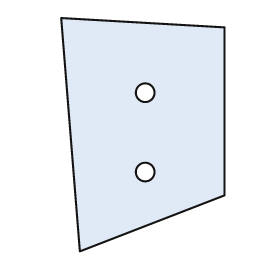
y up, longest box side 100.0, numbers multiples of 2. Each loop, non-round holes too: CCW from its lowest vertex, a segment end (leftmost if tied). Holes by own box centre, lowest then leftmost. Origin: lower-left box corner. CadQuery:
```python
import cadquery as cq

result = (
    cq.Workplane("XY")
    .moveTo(8.0, 0.0)
    .lineTo(70.0, 24.0)
    .lineTo(70.0, 96.0)
    .lineTo(0.0, 100.0)
    .close()
    .moveTo(36.0, 34.0)
    .circle(4.0)
    .moveTo(36.0, 68.0)
    .circle(4.0)
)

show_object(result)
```